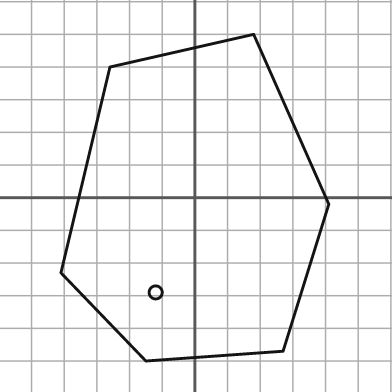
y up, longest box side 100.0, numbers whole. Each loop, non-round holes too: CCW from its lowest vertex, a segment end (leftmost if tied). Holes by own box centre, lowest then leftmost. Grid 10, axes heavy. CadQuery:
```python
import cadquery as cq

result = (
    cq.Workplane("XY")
    .moveTo(-15.0, -50.0)
    .lineTo(27.0, -47.0)
    .lineTo(41.0, -2.0)
    .lineTo(18.0, 50.0)
    .lineTo(-26.0, 40.0)
    .lineTo(-41.0, -23.0)
    .close()
    .moveTo(-12.0, -29.0)
    .circle(2.0)
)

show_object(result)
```